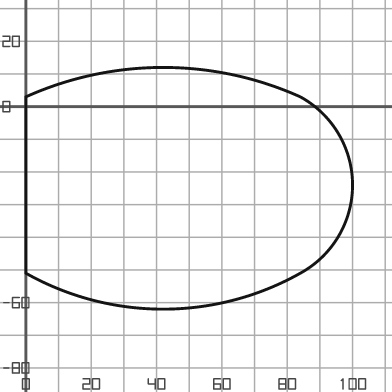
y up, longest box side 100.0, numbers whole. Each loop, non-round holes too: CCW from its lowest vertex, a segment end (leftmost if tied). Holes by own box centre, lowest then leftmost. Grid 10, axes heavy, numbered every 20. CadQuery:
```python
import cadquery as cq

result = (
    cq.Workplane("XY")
    .moveTo(0.0, -51.0)
    .threePointArc((42.0, -62.0), (84.0, -51.0))
    .threePointArc((100.0, -24.0), (84.0, 3.0))
    .threePointArc((42.0, 12.0), (0.0, 3.0))
    .close()
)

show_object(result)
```